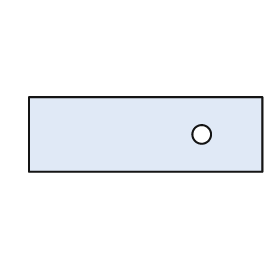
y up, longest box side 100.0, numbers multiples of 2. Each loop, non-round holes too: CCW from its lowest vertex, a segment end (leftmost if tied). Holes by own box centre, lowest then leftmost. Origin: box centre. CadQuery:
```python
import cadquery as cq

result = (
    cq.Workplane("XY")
    .moveTo(-50.0, -16.0)
    .lineTo(50.0, -16.0)
    .lineTo(50.0, 16.0)
    .lineTo(-50.0, 16.0)
    .close()
    .moveTo(24.0, 0.0)
    .circle(4.0)
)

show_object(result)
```